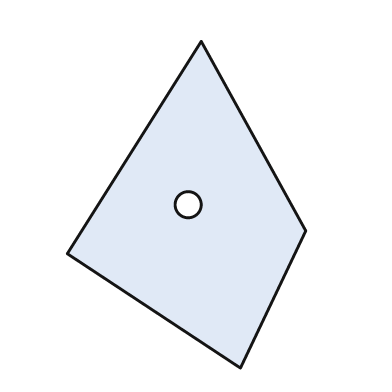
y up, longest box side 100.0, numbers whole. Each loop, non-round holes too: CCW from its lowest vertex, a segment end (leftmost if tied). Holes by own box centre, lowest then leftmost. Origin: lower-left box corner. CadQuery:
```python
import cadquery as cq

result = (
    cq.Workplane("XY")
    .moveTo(53.0, 0.0)
    .lineTo(73.0, 42.0)
    .lineTo(41.0, 100.0)
    .lineTo(0.0, 35.0)
    .close()
    .moveTo(37.0, 50.0)
    .circle(4.0)
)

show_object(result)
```